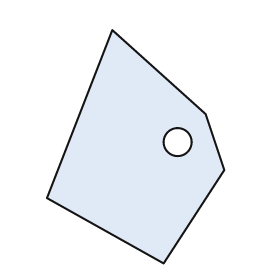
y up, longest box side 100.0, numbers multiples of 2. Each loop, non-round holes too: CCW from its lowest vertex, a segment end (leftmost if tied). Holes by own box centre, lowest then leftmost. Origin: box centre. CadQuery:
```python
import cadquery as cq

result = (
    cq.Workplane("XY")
    .moveTo(12.0, -50.0)
    .lineTo(38.0, -10.0)
    .lineTo(30.0, 14.0)
    .lineTo(-10.0, 50.0)
    .lineTo(-38.0, -22.0)
    .close()
    .moveTo(18.0, 2.0)
    .circle(6.0)
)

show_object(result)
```